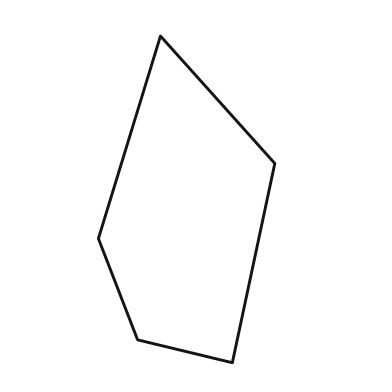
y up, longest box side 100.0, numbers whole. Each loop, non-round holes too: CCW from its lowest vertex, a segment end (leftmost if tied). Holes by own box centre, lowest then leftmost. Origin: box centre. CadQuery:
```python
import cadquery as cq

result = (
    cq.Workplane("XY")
    .moveTo(14.0, -50.0)
    .lineTo(27.0, 11.0)
    .lineTo(-8.0, 50.0)
    .lineTo(-27.0, -12.0)
    .lineTo(-15.0, -43.0)
    .close()
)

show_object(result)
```